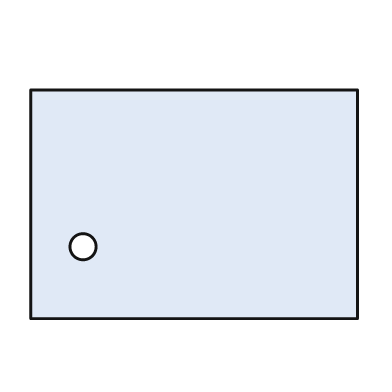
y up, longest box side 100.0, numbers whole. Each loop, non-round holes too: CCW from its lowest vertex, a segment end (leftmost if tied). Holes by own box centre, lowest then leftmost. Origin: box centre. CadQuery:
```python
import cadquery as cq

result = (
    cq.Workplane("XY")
    .moveTo(-50.0, -35.0)
    .lineTo(50.0, -35.0)
    .lineTo(50.0, 35.0)
    .lineTo(-50.0, 35.0)
    .close()
    .moveTo(-34.0, -13.0)
    .circle(4.0)
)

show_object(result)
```